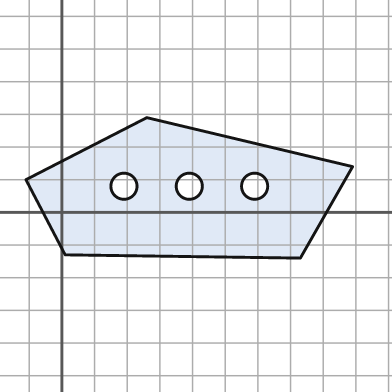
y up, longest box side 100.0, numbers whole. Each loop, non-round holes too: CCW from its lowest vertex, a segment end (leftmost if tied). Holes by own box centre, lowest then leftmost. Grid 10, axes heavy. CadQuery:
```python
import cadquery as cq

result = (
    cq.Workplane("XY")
    .moveTo(73.0, -14.0)
    .lineTo(89.0, 14.0)
    .lineTo(26.0, 29.0)
    .lineTo(-11.0, 10.0)
    .lineTo(1.0, -13.0)
    .close()
    .moveTo(19.0, 8.0)
    .circle(4.0)
    .moveTo(39.0, 8.0)
    .circle(4.0)
    .moveTo(59.0, 8.0)
    .circle(4.0)
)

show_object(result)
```